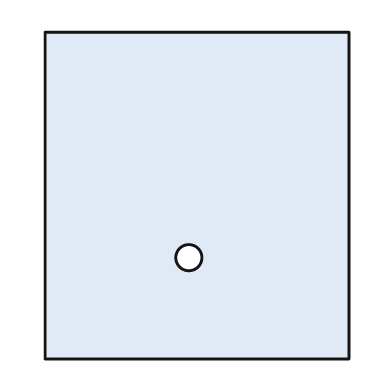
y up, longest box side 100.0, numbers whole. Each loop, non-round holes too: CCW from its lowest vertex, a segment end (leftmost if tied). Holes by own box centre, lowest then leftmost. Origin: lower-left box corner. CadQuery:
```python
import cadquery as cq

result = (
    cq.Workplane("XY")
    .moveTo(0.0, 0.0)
    .lineTo(93.0, 0.0)
    .lineTo(93.0, 100.0)
    .lineTo(0.0, 100.0)
    .close()
    .moveTo(44.0, 31.0)
    .circle(4.0)
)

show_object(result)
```